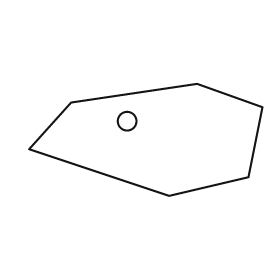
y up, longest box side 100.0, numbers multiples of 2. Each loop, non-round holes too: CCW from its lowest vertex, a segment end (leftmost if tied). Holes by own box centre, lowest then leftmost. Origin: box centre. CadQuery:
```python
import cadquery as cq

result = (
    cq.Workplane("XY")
    .moveTo(10.0, -24.0)
    .lineTo(44.0, -16.0)
    .lineTo(50.0, 14.0)
    .lineTo(22.0, 24.0)
    .lineTo(-32.0, 16.0)
    .lineTo(-50.0, -4.0)
    .close()
    .moveTo(-8.0, 8.0)
    .circle(4.0)
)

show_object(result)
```